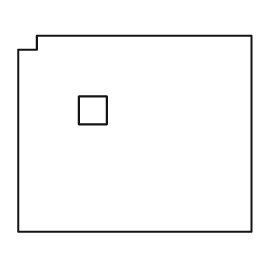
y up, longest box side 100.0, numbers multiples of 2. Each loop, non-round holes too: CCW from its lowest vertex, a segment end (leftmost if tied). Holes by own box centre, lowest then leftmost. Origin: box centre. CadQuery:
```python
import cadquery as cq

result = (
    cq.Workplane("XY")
    .moveTo(-50.0, -42.0)
    .lineTo(50.0, -42.0)
    .lineTo(50.0, 42.0)
    .lineTo(-42.0, 42.0)
    .lineTo(-42.0, 36.0)
    .lineTo(-50.0, 36.0)
    .close()
    .moveTo(-24.0, 4.0)
    .lineTo(-12.0, 4.0)
    .lineTo(-12.0, 16.0)
    .lineTo(-24.0, 16.0)
    .close()
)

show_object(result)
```